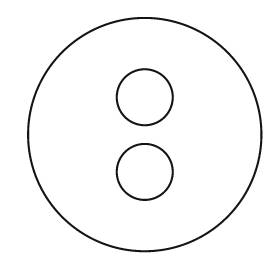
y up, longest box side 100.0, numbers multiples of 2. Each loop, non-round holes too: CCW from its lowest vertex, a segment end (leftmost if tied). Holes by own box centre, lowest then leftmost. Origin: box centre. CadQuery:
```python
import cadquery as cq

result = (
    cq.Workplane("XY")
    .moveTo(0.0, 0.0)
    .circle(50.0)
    .moveTo(0.0, -16.0)
    .circle(12.0)
    .moveTo(0.0, 16.0)
    .circle(12.0)
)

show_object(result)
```